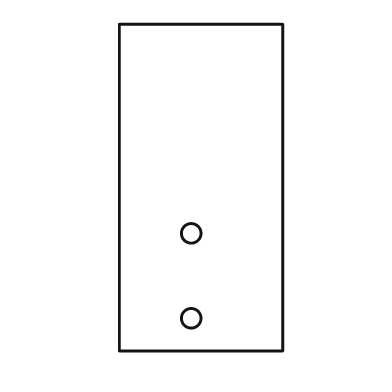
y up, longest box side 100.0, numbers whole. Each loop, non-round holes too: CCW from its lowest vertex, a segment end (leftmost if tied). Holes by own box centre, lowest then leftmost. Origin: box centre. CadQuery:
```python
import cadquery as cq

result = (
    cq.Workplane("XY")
    .moveTo(-25.0, -50.0)
    .lineTo(25.0, -50.0)
    .lineTo(25.0, 50.0)
    .lineTo(-25.0, 50.0)
    .close()
    .moveTo(-3.0, -40.0)
    .circle(3.0)
    .moveTo(-3.0, -14.0)
    .circle(3.0)
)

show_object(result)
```